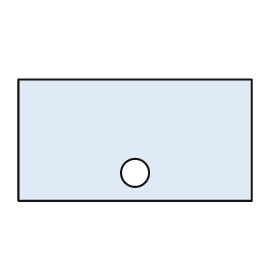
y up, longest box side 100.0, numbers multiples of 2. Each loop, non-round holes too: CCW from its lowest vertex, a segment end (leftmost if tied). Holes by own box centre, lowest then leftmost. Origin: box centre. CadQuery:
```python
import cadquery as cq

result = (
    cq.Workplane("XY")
    .moveTo(-50.0, -26.0)
    .lineTo(50.0, -26.0)
    .lineTo(50.0, 26.0)
    .lineTo(-50.0, 26.0)
    .close()
    .moveTo(0.0, -14.0)
    .circle(6.0)
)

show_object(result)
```